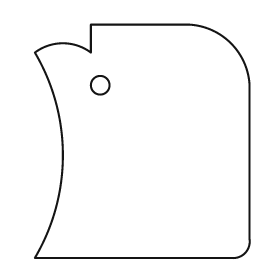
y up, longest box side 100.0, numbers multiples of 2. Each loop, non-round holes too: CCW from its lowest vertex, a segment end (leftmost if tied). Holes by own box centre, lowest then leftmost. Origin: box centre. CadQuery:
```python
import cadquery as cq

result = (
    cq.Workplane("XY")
    .moveTo(-46.0, -50.0)
    .lineTo(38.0, -50.0)
    .threePointArc((44.0, -48.0), (46.0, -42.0))
    .lineTo(46.0, 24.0)
    .threePointArc((38.0, 42.0), (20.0, 50.0))
    .lineTo(-22.0, 50.0)
    .lineTo(-22.0, 38.0)
    .threePointArc((-34.0, 42.0), (-46.0, 38.0))
    .threePointArc((-34.0, -6.0), (-46.0, -50.0))
    .close()
    .moveTo(-18.0, 24.0)
    .circle(4.0)
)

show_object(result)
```